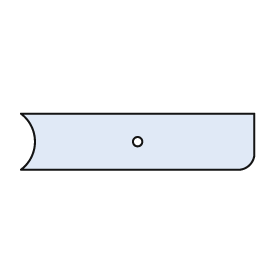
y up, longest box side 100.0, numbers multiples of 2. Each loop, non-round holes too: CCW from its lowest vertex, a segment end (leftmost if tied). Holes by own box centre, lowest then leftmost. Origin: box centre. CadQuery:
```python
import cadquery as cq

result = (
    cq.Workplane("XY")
    .moveTo(-50.0, -12.0)
    .lineTo(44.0, -12.0)
    .threePointArc((48.0, -10.0), (50.0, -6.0))
    .lineTo(50.0, 12.0)
    .lineTo(-50.0, 12.0)
    .threePointArc((-44.0, 0.0), (-50.0, -12.0))
    .close()
    .moveTo(0.0, 0.0)
    .circle(2.0)
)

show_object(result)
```